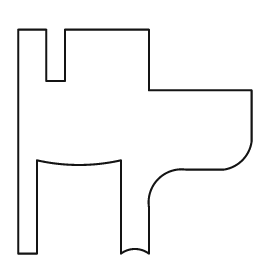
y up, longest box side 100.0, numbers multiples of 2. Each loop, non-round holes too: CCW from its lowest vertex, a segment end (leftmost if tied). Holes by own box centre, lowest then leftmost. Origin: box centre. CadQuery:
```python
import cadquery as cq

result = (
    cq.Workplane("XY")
    .moveTo(-50.0, -48.0)
    .lineTo(-42.0, -48.0)
    .lineTo(-42.0, -8.0)
    .threePointArc((-24.0, -10.0), (-6.0, -8.0))
    .lineTo(-6.0, -48.0)
    .threePointArc((0.0, -46.0), (6.0, -48.0))
    .lineTo(6.0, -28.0)
    .threePointArc((10.0, -16.0), (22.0, -12.0))
    .lineTo(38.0, -12.0)
    .threePointArc((46.0, -8.0), (50.0, 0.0))
    .lineTo(50.0, 22.0)
    .lineTo(6.0, 22.0)
    .lineTo(6.0, 48.0)
    .lineTo(-30.0, 48.0)
    .lineTo(-30.0, 26.0)
    .lineTo(-38.0, 26.0)
    .lineTo(-38.0, 48.0)
    .lineTo(-50.0, 48.0)
    .close()
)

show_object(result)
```